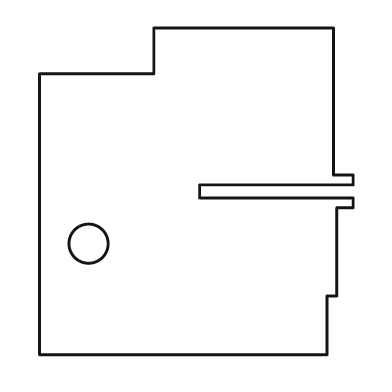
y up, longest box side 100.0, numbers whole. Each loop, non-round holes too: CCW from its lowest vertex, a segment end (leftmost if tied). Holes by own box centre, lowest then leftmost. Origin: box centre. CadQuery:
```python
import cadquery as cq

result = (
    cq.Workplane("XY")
    .moveTo(-48.0, -50.0)
    .lineTo(40.0, -50.0)
    .lineTo(40.0, -32.0)
    .lineTo(43.0, -32.0)
    .lineTo(43.0, -5.0)
    .lineTo(48.0, -5.0)
    .lineTo(48.0, -2.0)
    .lineTo(1.0, -2.0)
    .lineTo(1.0, 2.0)
    .lineTo(48.0, 2.0)
    .lineTo(48.0, 5.0)
    .lineTo(42.0, 5.0)
    .lineTo(42.0, 50.0)
    .lineTo(-13.0, 50.0)
    .lineTo(-13.0, 36.0)
    .lineTo(-48.0, 36.0)
    .close()
    .moveTo(-33.0, -16.0)
    .circle(6.0)
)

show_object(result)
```